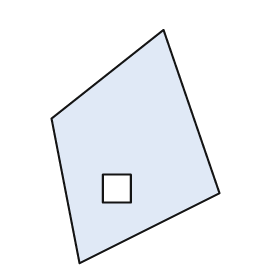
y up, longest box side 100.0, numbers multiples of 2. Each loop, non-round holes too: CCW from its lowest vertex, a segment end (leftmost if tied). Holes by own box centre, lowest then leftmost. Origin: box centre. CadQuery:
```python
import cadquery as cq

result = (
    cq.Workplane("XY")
    .moveTo(-24.0, -50.0)
    .lineTo(36.0, -20.0)
    .lineTo(12.0, 50.0)
    .lineTo(-36.0, 12.0)
    .close()
    .moveTo(-14.0, -24.0)
    .lineTo(-2.0, -24.0)
    .lineTo(-2.0, -12.0)
    .lineTo(-14.0, -12.0)
    .close()
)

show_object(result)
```